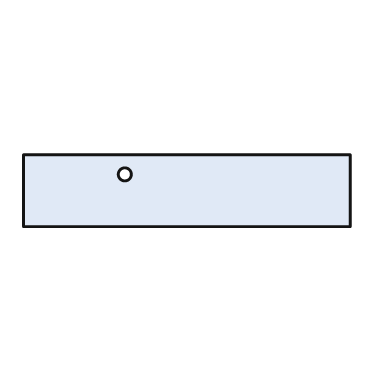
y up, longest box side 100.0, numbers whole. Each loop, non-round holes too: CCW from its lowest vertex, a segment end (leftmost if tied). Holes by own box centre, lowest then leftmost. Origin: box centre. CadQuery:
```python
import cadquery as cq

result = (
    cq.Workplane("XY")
    .moveTo(-50.0, -11.0)
    .lineTo(50.0, -11.0)
    .lineTo(50.0, 11.0)
    .lineTo(-50.0, 11.0)
    .close()
    .moveTo(-19.0, 5.0)
    .circle(2.0)
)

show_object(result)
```